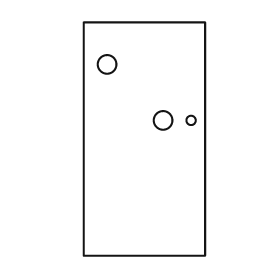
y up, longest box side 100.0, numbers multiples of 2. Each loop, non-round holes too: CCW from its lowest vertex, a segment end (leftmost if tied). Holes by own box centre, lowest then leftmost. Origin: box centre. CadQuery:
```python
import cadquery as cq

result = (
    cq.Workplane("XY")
    .moveTo(-26.0, -50.0)
    .lineTo(26.0, -50.0)
    .lineTo(26.0, 50.0)
    .lineTo(-26.0, 50.0)
    .close()
    .moveTo(8.0, 8.0)
    .circle(4.0)
    .moveTo(20.0, 8.0)
    .circle(2.0)
    .moveTo(-16.0, 32.0)
    .circle(4.0)
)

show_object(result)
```